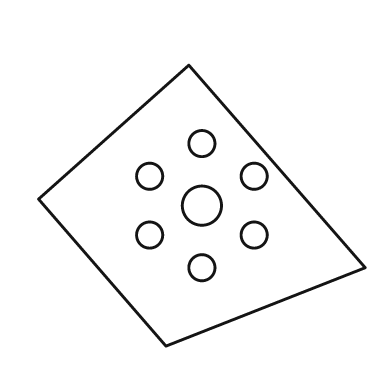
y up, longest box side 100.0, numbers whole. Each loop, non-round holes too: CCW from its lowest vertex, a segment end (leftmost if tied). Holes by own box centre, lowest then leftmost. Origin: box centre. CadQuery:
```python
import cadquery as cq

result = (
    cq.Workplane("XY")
    .moveTo(-11.0, -43.0)
    .lineTo(50.0, -19.0)
    .lineTo(-4.0, 43.0)
    .lineTo(-50.0, 2.0)
    .close()
    .moveTo(0.0, -19.0)
    .circle(4.0)
    .moveTo(-16.0, -9.0)
    .circle(4.0)
    .moveTo(16.0, -9.0)
    .circle(4.0)
    .moveTo(0.0, 0.0)
    .circle(6.0)
    .moveTo(-16.0, 9.0)
    .circle(4.0)
    .moveTo(16.0, 9.0)
    .circle(4.0)
    .moveTo(0.0, 19.0)
    .circle(4.0)
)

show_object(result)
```